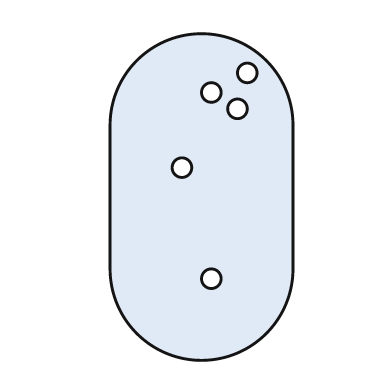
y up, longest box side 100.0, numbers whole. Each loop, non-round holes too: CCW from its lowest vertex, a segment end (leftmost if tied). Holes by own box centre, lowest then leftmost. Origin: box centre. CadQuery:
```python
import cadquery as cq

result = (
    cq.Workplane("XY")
    .moveTo(-28.0, -22.0)
    .threePointArc((0.0, -50.0), (28.0, -22.0))
    .lineTo(28.0, 22.0)
    .threePointArc((0.0, 50.0), (-28.0, 22.0))
    .close()
    .moveTo(3.0, -25.0)
    .circle(3.0)
    .moveTo(-6.0, 9.0)
    .circle(3.0)
    .moveTo(11.0, 27.0)
    .circle(3.0)
    .moveTo(3.0, 32.0)
    .circle(3.0)
    .moveTo(14.0, 38.0)
    .circle(3.0)
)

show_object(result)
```